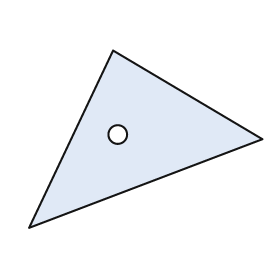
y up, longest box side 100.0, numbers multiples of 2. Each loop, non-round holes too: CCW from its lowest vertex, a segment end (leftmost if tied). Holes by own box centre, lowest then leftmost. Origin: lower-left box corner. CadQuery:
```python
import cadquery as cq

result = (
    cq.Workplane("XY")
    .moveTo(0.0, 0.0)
    .lineTo(100.0, 38.0)
    .lineTo(36.0, 76.0)
    .close()
    .moveTo(38.0, 40.0)
    .circle(4.0)
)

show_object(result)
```